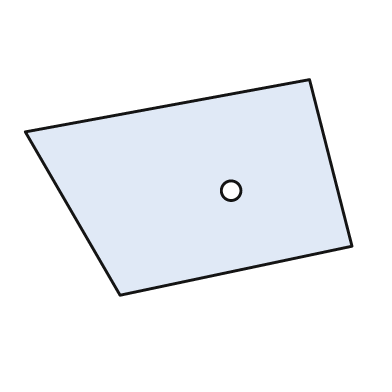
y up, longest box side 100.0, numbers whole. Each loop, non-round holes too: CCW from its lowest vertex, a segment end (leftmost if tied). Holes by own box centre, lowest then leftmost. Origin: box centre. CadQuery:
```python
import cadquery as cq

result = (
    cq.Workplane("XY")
    .moveTo(-21.0, -33.0)
    .lineTo(50.0, -18.0)
    .lineTo(37.0, 33.0)
    .lineTo(-50.0, 17.0)
    .close()
    .moveTo(13.0, -1.0)
    .circle(3.0)
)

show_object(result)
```